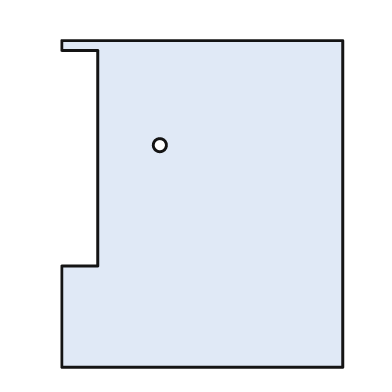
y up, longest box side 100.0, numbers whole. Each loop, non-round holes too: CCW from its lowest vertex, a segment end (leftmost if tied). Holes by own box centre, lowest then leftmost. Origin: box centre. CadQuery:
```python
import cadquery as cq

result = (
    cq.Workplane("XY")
    .moveTo(-43.0, -50.0)
    .lineTo(43.0, -50.0)
    .lineTo(43.0, 50.0)
    .lineTo(-43.0, 50.0)
    .lineTo(-43.0, 47.0)
    .lineTo(-32.0, 47.0)
    .lineTo(-32.0, -19.0)
    .lineTo(-43.0, -19.0)
    .close()
    .moveTo(-13.0, 18.0)
    .circle(2.0)
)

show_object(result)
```